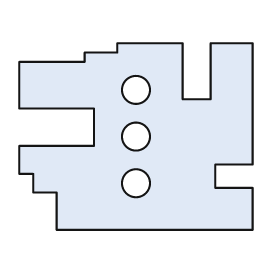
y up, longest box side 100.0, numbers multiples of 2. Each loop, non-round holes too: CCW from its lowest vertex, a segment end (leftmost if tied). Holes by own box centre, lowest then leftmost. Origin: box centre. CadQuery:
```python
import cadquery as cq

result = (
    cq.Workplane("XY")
    .moveTo(-34.0, -40.0)
    .lineTo(50.0, -40.0)
    .lineTo(50.0, -22.0)
    .lineTo(34.0, -22.0)
    .lineTo(34.0, -12.0)
    .lineTo(50.0, -12.0)
    .lineTo(50.0, 40.0)
    .lineTo(32.0, 40.0)
    .lineTo(32.0, 16.0)
    .lineTo(20.0, 16.0)
    .lineTo(20.0, 40.0)
    .lineTo(-8.0, 40.0)
    .lineTo(-8.0, 36.0)
    .lineTo(-22.0, 36.0)
    .lineTo(-22.0, 32.0)
    .lineTo(-50.0, 32.0)
    .lineTo(-50.0, 12.0)
    .lineTo(-18.0, 12.0)
    .lineTo(-18.0, -4.0)
    .lineTo(-50.0, -4.0)
    .lineTo(-50.0, -16.0)
    .lineTo(-44.0, -16.0)
    .lineTo(-44.0, -24.0)
    .lineTo(-34.0, -24.0)
    .close()
    .moveTo(0.0, -20.0)
    .circle(6.0)
    .moveTo(0.0, 0.0)
    .circle(6.0)
    .moveTo(0.0, 20.0)
    .circle(6.0)
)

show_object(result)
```